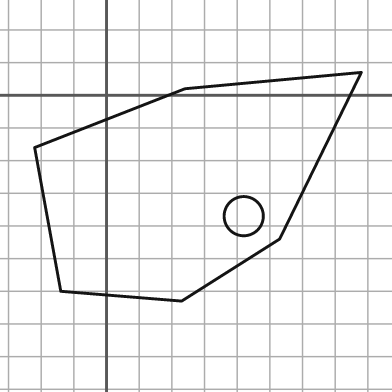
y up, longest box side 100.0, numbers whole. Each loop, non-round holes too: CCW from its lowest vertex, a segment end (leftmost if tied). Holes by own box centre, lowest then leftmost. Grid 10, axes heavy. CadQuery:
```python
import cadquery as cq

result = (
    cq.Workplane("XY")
    .moveTo(23.0, -63.0)
    .lineTo(53.0, -44.0)
    .lineTo(78.0, 7.0)
    .lineTo(24.0, 2.0)
    .lineTo(-22.0, -16.0)
    .lineTo(-14.0, -60.0)
    .close()
    .moveTo(42.0, -37.0)
    .circle(6.0)
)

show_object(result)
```